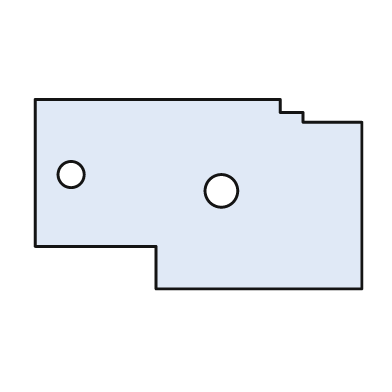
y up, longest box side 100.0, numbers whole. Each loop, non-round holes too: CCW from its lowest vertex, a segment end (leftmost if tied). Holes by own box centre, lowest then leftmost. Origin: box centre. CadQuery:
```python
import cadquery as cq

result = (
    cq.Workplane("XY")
    .moveTo(-13.0, -29.0)
    .lineTo(50.0, -29.0)
    .lineTo(50.0, 22.0)
    .lineTo(32.0, 22.0)
    .lineTo(32.0, 25.0)
    .lineTo(25.0, 25.0)
    .lineTo(25.0, 29.0)
    .lineTo(-50.0, 29.0)
    .lineTo(-50.0, -16.0)
    .lineTo(-13.0, -16.0)
    .close()
    .moveTo(7.0, 1.0)
    .circle(5.0)
    .moveTo(-39.0, 6.0)
    .circle(4.0)
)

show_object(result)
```